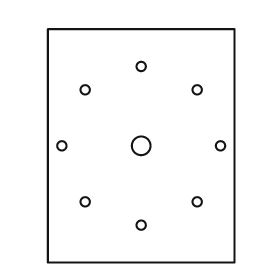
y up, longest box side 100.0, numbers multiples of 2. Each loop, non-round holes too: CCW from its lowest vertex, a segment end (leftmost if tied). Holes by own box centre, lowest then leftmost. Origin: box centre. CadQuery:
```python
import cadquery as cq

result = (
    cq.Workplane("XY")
    .moveTo(-40.0, -50.0)
    .lineTo(40.0, -50.0)
    .lineTo(40.0, 50.0)
    .lineTo(-40.0, 50.0)
    .close()
    .moveTo(0.0, -34.0)
    .circle(2.0)
    .moveTo(-24.0, -24.0)
    .circle(2.0)
    .moveTo(24.0, -24.0)
    .circle(2.0)
    .moveTo(-34.0, 0.0)
    .circle(2.0)
    .moveTo(0.0, 0.0)
    .circle(4.0)
    .moveTo(34.0, 0.0)
    .circle(2.0)
    .moveTo(-24.0, 24.0)
    .circle(2.0)
    .moveTo(24.0, 24.0)
    .circle(2.0)
    .moveTo(0.0, 34.0)
    .circle(2.0)
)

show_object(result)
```